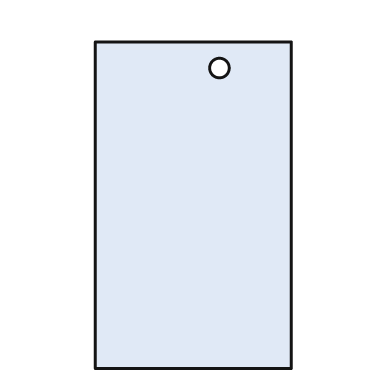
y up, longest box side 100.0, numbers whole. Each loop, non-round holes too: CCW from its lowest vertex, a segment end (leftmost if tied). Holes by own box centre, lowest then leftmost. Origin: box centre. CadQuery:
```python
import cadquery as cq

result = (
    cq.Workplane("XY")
    .moveTo(-30.0, -50.0)
    .lineTo(30.0, -50.0)
    .lineTo(30.0, 50.0)
    .lineTo(-30.0, 50.0)
    .close()
    .moveTo(8.0, 42.0)
    .circle(3.0)
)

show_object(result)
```